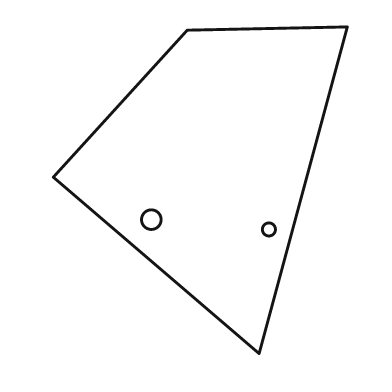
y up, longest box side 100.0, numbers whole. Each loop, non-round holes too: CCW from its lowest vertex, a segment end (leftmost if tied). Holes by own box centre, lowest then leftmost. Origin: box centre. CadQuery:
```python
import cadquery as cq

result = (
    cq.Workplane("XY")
    .moveTo(18.0, -50.0)
    .lineTo(45.0, 50.0)
    .lineTo(-4.0, 49.0)
    .lineTo(-45.0, 4.0)
    .close()
    .moveTo(21.0, -12.0)
    .circle(2.0)
    .moveTo(-15.0, -9.0)
    .circle(3.0)
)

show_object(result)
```